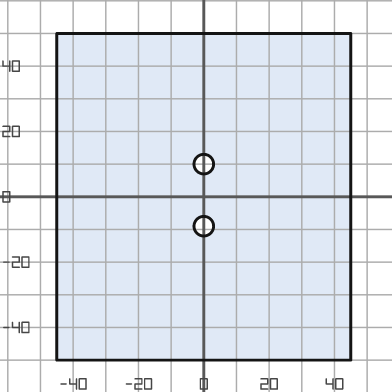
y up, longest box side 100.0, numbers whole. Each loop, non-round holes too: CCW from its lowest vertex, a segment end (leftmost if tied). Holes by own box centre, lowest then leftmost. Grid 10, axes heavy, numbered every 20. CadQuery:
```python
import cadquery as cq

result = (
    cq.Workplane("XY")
    .moveTo(-45.0, -50.0)
    .lineTo(45.0, -50.0)
    .lineTo(45.0, 50.0)
    .lineTo(-45.0, 50.0)
    .close()
    .moveTo(0.0, -9.0)
    .circle(3.0)
    .moveTo(0.0, 10.0)
    .circle(3.0)
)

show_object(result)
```